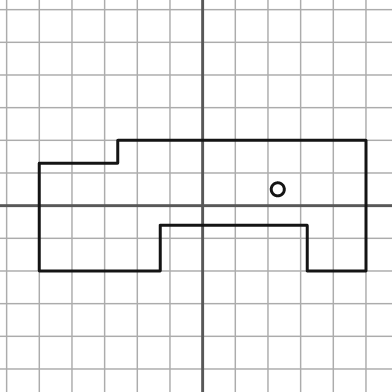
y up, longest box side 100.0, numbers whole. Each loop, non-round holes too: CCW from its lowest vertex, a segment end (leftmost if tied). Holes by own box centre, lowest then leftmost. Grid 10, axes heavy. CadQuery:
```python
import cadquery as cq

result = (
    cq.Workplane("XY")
    .moveTo(-50.0, -20.0)
    .lineTo(-13.0, -20.0)
    .lineTo(-13.0, -6.0)
    .lineTo(32.0, -6.0)
    .lineTo(32.0, -20.0)
    .lineTo(50.0, -20.0)
    .lineTo(50.0, 20.0)
    .lineTo(-26.0, 20.0)
    .lineTo(-26.0, 13.0)
    .lineTo(-50.0, 13.0)
    .close()
    .moveTo(23.0, 5.0)
    .circle(2.0)
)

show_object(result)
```